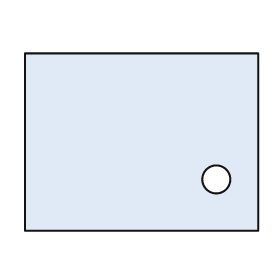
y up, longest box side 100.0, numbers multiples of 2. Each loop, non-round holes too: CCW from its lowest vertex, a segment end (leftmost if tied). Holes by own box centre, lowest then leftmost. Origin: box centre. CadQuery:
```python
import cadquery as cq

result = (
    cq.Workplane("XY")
    .moveTo(-50.0, -38.0)
    .lineTo(50.0, -38.0)
    .lineTo(50.0, 38.0)
    .lineTo(-50.0, 38.0)
    .close()
    .moveTo(32.0, -16.0)
    .circle(6.0)
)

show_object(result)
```